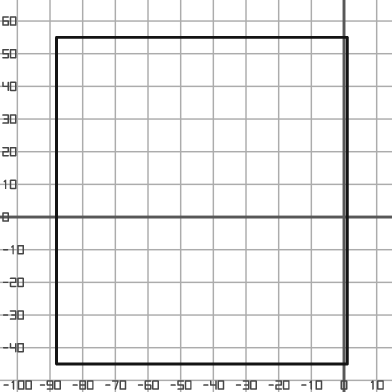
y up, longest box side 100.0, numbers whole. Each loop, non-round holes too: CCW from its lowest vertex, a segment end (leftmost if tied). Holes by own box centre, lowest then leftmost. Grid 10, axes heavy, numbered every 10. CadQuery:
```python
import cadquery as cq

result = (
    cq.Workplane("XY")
    .moveTo(-88.0, -45.0)
    .lineTo(1.0, -45.0)
    .lineTo(1.0, 55.0)
    .lineTo(-88.0, 55.0)
    .close()
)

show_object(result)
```